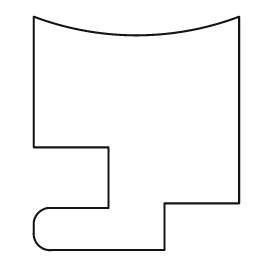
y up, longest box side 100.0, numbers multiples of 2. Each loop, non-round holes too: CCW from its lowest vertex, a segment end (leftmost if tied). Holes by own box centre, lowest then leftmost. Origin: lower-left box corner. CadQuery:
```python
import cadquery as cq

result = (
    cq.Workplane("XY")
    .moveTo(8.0, 0.0)
    .lineTo(56.0, 0.0)
    .lineTo(56.0, 20.0)
    .lineTo(88.0, 20.0)
    .lineTo(88.0, 100.0)
    .threePointArc((44.0, 92.0), (0.0, 100.0))
    .lineTo(0.0, 44.0)
    .lineTo(32.0, 44.0)
    .lineTo(32.0, 18.0)
    .lineTo(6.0, 18.0)
    .threePointArc((2.0, 16.0), (0.0, 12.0))
    .lineTo(0.0, 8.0)
    .threePointArc((2.0, 2.0), (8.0, 0.0))
    .close()
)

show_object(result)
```